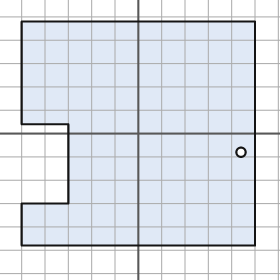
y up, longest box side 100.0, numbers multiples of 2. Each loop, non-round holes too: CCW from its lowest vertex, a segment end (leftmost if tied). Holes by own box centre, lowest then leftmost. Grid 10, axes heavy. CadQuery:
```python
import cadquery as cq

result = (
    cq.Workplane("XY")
    .moveTo(-50.0, -48.0)
    .lineTo(50.0, -48.0)
    .lineTo(50.0, 48.0)
    .lineTo(-50.0, 48.0)
    .lineTo(-50.0, 4.0)
    .lineTo(-30.0, 4.0)
    .lineTo(-30.0, -30.0)
    .lineTo(-50.0, -30.0)
    .close()
    .moveTo(44.0, -8.0)
    .circle(2.0)
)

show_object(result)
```